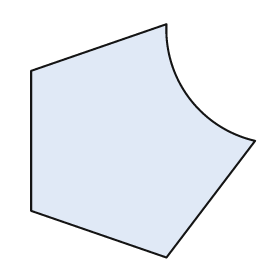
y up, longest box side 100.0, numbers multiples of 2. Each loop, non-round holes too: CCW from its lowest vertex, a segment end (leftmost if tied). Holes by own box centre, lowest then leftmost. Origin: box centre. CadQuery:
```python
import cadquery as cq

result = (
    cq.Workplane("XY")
    .moveTo(10.0, -50.0)
    .lineTo(48.0, 0.0)
    .threePointArc((20.0, 18.0), (10.0, 50.0))
    .lineTo(-48.0, 30.0)
    .lineTo(-48.0, -30.0)
    .close()
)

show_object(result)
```